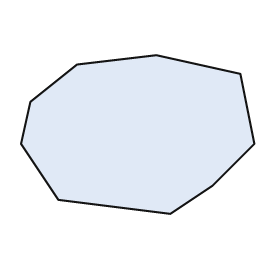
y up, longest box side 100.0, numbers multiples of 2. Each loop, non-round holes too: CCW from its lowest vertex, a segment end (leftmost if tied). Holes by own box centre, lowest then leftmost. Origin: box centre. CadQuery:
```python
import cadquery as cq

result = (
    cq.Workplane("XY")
    .moveTo(14.0, -34.0)
    .lineTo(32.0, -22.0)
    .lineTo(50.0, -4.0)
    .lineTo(44.0, 26.0)
    .lineTo(8.0, 34.0)
    .lineTo(-26.0, 30.0)
    .lineTo(-46.0, 14.0)
    .lineTo(-50.0, -4.0)
    .lineTo(-34.0, -28.0)
    .close()
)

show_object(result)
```